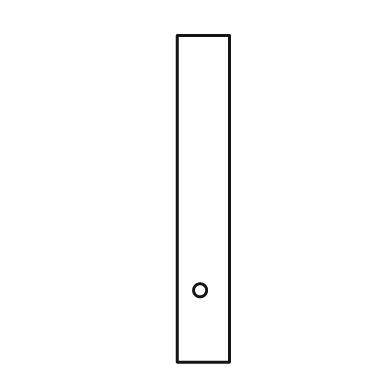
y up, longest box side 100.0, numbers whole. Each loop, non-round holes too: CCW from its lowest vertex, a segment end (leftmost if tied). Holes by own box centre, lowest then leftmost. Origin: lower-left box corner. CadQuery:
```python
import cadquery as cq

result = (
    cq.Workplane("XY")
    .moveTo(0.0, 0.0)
    .lineTo(16.0, 0.0)
    .lineTo(16.0, 100.0)
    .lineTo(0.0, 100.0)
    .close()
    .moveTo(7.0, 22.0)
    .circle(2.0)
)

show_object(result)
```